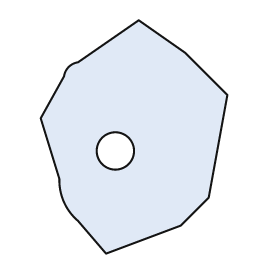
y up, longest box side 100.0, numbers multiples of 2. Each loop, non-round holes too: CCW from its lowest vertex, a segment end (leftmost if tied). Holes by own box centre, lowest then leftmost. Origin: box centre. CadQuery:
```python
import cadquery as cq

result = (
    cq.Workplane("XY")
    .moveTo(-12.0, -50.0)
    .lineTo(20.0, -38.0)
    .lineTo(32.0, -26.0)
    .lineTo(40.0, 18.0)
    .lineTo(22.0, 36.0)
    .lineTo(2.0, 50.0)
    .lineTo(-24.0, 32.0)
    .threePointArc((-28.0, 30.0), (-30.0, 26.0))
    .lineTo(-40.0, 8.0)
    .lineTo(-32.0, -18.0)
    .threePointArc((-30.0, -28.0), (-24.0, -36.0))
    .close()
    .moveTo(-8.0, -6.0)
    .circle(8.0)
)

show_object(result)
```